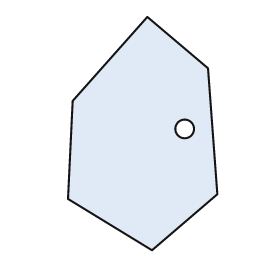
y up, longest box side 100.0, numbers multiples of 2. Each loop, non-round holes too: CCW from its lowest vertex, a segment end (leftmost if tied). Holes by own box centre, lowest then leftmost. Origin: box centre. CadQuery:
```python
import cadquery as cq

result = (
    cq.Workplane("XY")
    .moveTo(4.0, -50.0)
    .lineTo(32.0, -26.0)
    .lineTo(28.0, 28.0)
    .lineTo(2.0, 50.0)
    .lineTo(-30.0, 14.0)
    .lineTo(-32.0, -28.0)
    .close()
    .moveTo(18.0, 2.0)
    .circle(4.0)
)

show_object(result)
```